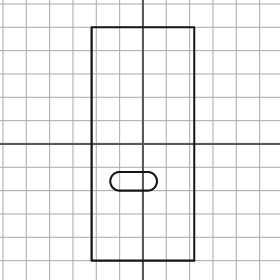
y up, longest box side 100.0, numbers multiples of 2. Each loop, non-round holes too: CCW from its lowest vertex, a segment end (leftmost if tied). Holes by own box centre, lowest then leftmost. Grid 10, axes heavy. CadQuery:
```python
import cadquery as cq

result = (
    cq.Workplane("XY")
    .moveTo(-22.0, -50.0)
    .lineTo(22.0, -50.0)
    .lineTo(22.0, 50.0)
    .lineTo(-22.0, 50.0)
    .close()
    .moveTo(-10.0, -20.0)
    .lineTo(2.0, -20.0)
    .threePointArc((6.0, -16.0), (2.0, -12.0))
    .lineTo(-10.0, -12.0)
    .threePointArc((-14.0, -16.0), (-10.0, -20.0))
    .close()
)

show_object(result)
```